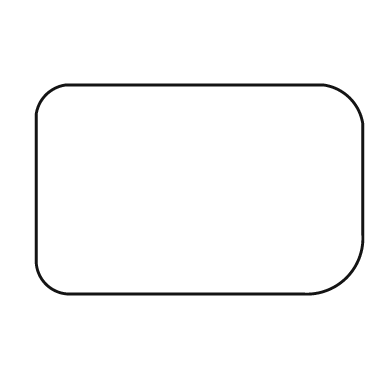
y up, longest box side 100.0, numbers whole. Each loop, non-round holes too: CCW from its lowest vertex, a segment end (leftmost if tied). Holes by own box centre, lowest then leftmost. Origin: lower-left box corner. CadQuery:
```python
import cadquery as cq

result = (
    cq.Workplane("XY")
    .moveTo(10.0, 0.0)
    .lineTo(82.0, 0.0)
    .threePointArc((95.0, 5.0), (100.0, 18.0))
    .lineTo(100.0, 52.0)
    .threePointArc((96.0, 60.0), (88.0, 64.0))
    .lineTo(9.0, 64.0)
    .threePointArc((3.0, 61.0), (0.0, 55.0))
    .lineTo(0.0, 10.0)
    .threePointArc((3.0, 3.0), (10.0, 0.0))
    .close()
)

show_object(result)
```